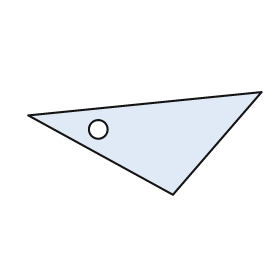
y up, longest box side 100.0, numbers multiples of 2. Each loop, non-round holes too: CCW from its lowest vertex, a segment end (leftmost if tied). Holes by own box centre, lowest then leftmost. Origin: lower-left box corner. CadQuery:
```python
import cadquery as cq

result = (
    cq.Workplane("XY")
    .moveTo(62.0, 0.0)
    .lineTo(100.0, 44.0)
    .lineTo(0.0, 34.0)
    .close()
    .moveTo(30.0, 28.0)
    .circle(4.0)
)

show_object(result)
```